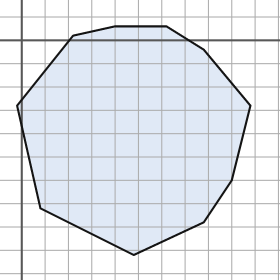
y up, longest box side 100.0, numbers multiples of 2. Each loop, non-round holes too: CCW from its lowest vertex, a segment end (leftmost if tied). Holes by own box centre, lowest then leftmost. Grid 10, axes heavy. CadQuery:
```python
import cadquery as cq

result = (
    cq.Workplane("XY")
    .moveTo(48.0, -92.0)
    .lineTo(78.0, -78.0)
    .lineTo(90.0, -60.0)
    .lineTo(98.0, -28.0)
    .lineTo(78.0, -4.0)
    .lineTo(62.0, 6.0)
    .lineTo(40.0, 6.0)
    .lineTo(22.0, 2.0)
    .lineTo(-2.0, -28.0)
    .lineTo(8.0, -72.0)
    .close()
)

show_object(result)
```